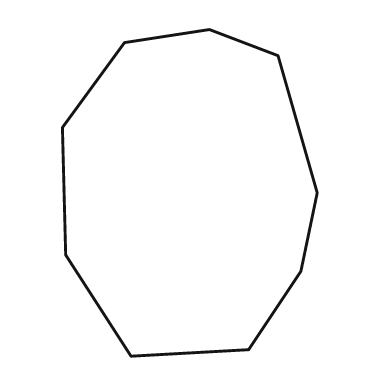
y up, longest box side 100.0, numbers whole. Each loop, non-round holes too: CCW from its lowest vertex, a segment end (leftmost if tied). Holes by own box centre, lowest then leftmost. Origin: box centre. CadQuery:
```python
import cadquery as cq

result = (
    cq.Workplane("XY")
    .moveTo(-18.0, -50.0)
    .lineTo(18.0, -48.0)
    .lineTo(34.0, -24.0)
    .lineTo(39.0, 0.0)
    .lineTo(27.0, 42.0)
    .lineTo(6.0, 50.0)
    .lineTo(-20.0, 46.0)
    .lineTo(-39.0, 20.0)
    .lineTo(-38.0, -19.0)
    .close()
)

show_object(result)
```